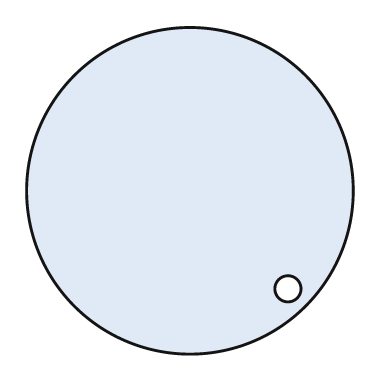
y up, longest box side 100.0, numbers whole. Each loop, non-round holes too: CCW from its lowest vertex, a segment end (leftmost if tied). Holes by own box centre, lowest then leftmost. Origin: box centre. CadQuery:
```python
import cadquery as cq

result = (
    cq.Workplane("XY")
    .moveTo(0.0, 0.0)
    .circle(50.0)
    .moveTo(30.0, -30.0)
    .circle(4.0)
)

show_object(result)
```